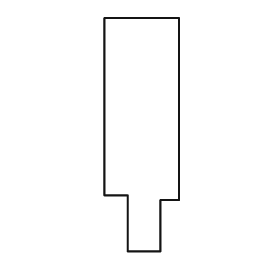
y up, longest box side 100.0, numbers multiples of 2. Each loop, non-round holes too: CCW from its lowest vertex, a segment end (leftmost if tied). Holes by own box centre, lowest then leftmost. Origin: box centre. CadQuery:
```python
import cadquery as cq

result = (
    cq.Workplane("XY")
    .moveTo(-6.0, -50.0)
    .lineTo(8.0, -50.0)
    .lineTo(8.0, -28.0)
    .lineTo(16.0, -28.0)
    .lineTo(16.0, 50.0)
    .lineTo(-16.0, 50.0)
    .lineTo(-16.0, -26.0)
    .lineTo(-6.0, -26.0)
    .close()
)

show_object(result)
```